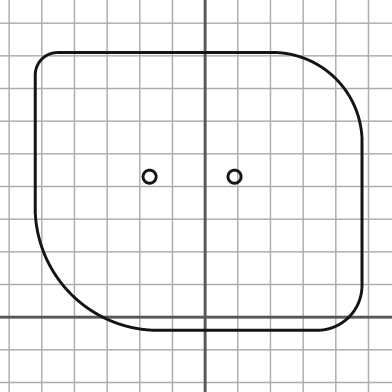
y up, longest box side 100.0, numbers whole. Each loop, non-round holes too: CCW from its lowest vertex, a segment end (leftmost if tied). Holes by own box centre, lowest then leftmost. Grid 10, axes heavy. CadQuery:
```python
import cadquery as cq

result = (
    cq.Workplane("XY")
    .moveTo(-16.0, -4.0)
    .lineTo(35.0, -4.0)
    .threePointArc((44.0, 0.0), (48.0, 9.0))
    .lineTo(48.0, 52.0)
    .threePointArc((40.0, 73.0), (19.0, 81.0))
    .lineTo(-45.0, 81.0)
    .threePointArc((-50.0, 79.0), (-52.0, 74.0))
    .lineTo(-52.0, 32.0)
    .threePointArc((-41.0, 7.0), (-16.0, -4.0))
    .close()
    .moveTo(-17.0, 43.0)
    .circle(2.0)
    .moveTo(9.0, 43.0)
    .circle(2.0)
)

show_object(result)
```